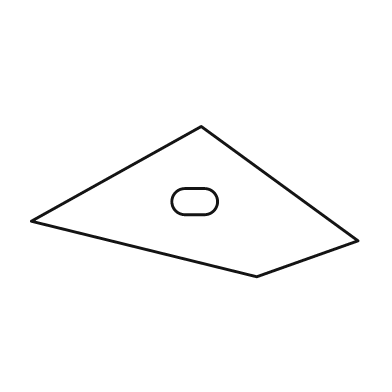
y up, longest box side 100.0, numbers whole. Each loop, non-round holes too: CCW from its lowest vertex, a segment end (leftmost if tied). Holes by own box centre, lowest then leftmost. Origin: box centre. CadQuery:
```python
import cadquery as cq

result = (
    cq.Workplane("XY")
    .moveTo(19.0, -23.0)
    .lineTo(50.0, -12.0)
    .lineTo(2.0, 23.0)
    .lineTo(-50.0, -6.0)
    .close()
    .moveTo(-3.0, -4.0)
    .lineTo(3.0, -4.0)
    .threePointArc((7.0, 0.0), (3.0, 4.0))
    .lineTo(-3.0, 4.0)
    .threePointArc((-7.0, 0.0), (-3.0, -4.0))
    .close()
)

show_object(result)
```